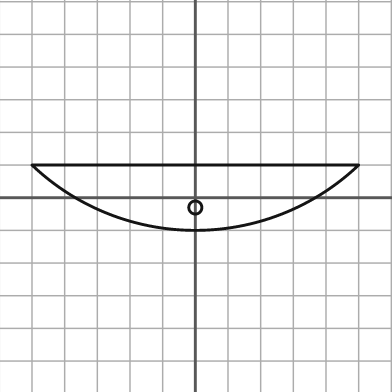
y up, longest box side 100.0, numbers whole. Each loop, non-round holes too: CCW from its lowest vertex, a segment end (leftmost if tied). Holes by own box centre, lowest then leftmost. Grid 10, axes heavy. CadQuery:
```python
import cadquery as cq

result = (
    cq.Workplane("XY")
    .moveTo(-50.0, 10.0)
    .threePointArc((0.0, -10.0), (50.0, 10.0))
    .close()
    .moveTo(0.0, -3.0)
    .circle(2.0)
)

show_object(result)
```